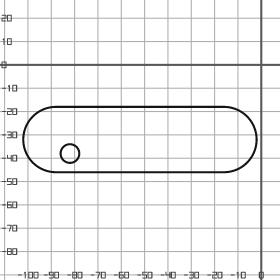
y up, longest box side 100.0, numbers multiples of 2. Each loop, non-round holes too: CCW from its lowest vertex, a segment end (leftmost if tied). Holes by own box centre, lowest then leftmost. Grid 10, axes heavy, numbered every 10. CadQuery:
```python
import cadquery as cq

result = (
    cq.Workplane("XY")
    .moveTo(-88.0, -46.0)
    .lineTo(-16.0, -46.0)
    .threePointArc((-2.0, -32.0), (-16.0, -18.0))
    .lineTo(-88.0, -18.0)
    .threePointArc((-102.0, -32.0), (-88.0, -46.0))
    .close()
    .moveTo(-82.0, -38.0)
    .circle(4.0)
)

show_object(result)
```